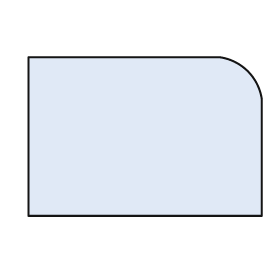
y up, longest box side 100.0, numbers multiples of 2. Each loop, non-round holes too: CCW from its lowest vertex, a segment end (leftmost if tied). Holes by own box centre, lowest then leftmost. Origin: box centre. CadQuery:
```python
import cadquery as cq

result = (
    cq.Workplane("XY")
    .moveTo(-50.0, -34.0)
    .lineTo(50.0, -34.0)
    .lineTo(50.0, 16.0)
    .threePointArc((44.0, 28.0), (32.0, 34.0))
    .lineTo(-50.0, 34.0)
    .close()
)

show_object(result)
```